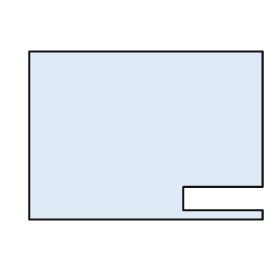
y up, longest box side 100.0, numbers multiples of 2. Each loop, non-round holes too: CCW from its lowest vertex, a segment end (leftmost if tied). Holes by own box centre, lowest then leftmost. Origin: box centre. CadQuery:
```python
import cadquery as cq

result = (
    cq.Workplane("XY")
    .moveTo(-50.0, -36.0)
    .lineTo(50.0, -36.0)
    .lineTo(50.0, -32.0)
    .lineTo(16.0, -32.0)
    .lineTo(16.0, -22.0)
    .lineTo(50.0, -22.0)
    .lineTo(50.0, 36.0)
    .lineTo(-50.0, 36.0)
    .close()
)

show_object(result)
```